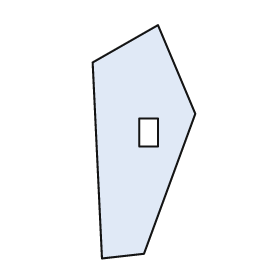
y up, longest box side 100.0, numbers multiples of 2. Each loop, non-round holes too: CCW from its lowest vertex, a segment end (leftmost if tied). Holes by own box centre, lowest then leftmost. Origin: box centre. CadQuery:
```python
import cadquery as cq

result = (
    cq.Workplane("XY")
    .moveTo(-18.0, -50.0)
    .lineTo(0.0, -48.0)
    .lineTo(22.0, 12.0)
    .lineTo(6.0, 50.0)
    .lineTo(-22.0, 34.0)
    .close()
    .moveTo(-2.0, -2.0)
    .lineTo(6.0, -2.0)
    .lineTo(6.0, 10.0)
    .lineTo(-2.0, 10.0)
    .close()
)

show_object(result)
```